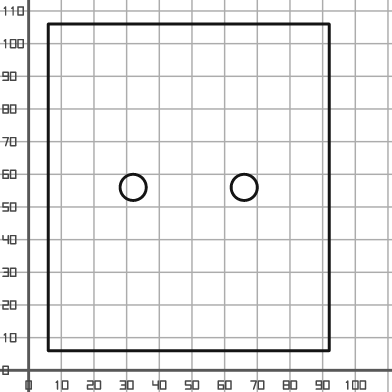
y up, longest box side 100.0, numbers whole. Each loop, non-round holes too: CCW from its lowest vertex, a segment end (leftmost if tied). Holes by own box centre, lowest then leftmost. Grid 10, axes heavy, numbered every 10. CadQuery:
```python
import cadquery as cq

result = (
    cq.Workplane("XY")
    .moveTo(6.0, 6.0)
    .lineTo(92.0, 6.0)
    .lineTo(92.0, 106.0)
    .lineTo(6.0, 106.0)
    .close()
    .moveTo(32.0, 56.0)
    .circle(4.0)
    .moveTo(66.0, 56.0)
    .circle(4.0)
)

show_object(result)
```